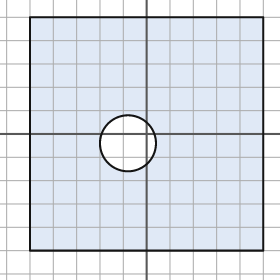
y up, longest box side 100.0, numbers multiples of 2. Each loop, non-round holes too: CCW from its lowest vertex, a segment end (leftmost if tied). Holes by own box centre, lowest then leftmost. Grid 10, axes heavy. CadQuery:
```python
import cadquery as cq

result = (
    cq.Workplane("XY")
    .moveTo(-50.0, -50.0)
    .lineTo(50.0, -50.0)
    .lineTo(50.0, 50.0)
    .lineTo(-50.0, 50.0)
    .close()
    .moveTo(-8.0, -4.0)
    .circle(12.0)
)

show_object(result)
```